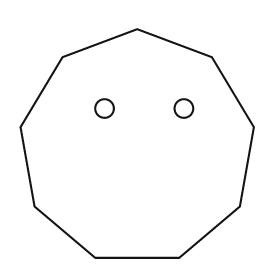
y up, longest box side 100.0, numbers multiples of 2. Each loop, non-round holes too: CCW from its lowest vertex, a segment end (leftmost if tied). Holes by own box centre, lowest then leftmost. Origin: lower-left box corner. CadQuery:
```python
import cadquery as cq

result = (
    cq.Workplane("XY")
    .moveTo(32.0, 0.0)
    .lineTo(68.0, 0.0)
    .lineTo(94.0, 22.0)
    .lineTo(100.0, 56.0)
    .lineTo(82.0, 86.0)
    .lineTo(50.0, 98.0)
    .lineTo(18.0, 86.0)
    .lineTo(0.0, 56.0)
    .lineTo(6.0, 22.0)
    .close()
    .moveTo(36.0, 64.0)
    .circle(4.0)
    .moveTo(70.0, 64.0)
    .circle(4.0)
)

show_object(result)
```